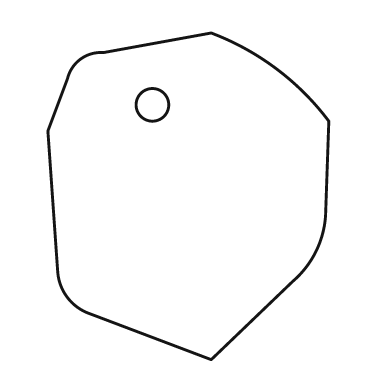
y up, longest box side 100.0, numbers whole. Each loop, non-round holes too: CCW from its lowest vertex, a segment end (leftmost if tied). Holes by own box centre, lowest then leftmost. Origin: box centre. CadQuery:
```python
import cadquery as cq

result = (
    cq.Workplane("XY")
    .moveTo(7.0, -50.0)
    .lineTo(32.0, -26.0)
    .threePointArc((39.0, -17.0), (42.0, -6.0))
    .lineTo(43.0, 23.0)
    .threePointArc((27.0, 39.0), (7.0, 50.0))
    .lineTo(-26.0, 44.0)
    .threePointArc((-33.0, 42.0), (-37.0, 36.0))
    .lineTo(-43.0, 20.0)
    .lineTo(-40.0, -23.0)
    .threePointArc((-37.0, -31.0), (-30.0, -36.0))
    .close()
    .moveTo(-11.0, 28.0)
    .circle(5.0)
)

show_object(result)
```